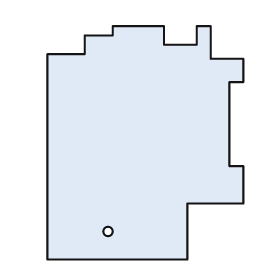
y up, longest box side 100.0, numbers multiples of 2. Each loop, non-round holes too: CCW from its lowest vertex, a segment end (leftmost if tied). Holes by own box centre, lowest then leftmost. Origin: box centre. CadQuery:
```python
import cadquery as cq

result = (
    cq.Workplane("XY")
    .moveTo(-42.0, -50.0)
    .lineTo(18.0, -50.0)
    .lineTo(18.0, -26.0)
    .lineTo(42.0, -26.0)
    .lineTo(42.0, -10.0)
    .lineTo(36.0, -10.0)
    .lineTo(36.0, 26.0)
    .lineTo(42.0, 26.0)
    .lineTo(42.0, 36.0)
    .lineTo(28.0, 36.0)
    .lineTo(28.0, 50.0)
    .lineTo(22.0, 50.0)
    .lineTo(22.0, 42.0)
    .lineTo(8.0, 42.0)
    .lineTo(8.0, 50.0)
    .lineTo(-14.0, 50.0)
    .lineTo(-14.0, 46.0)
    .lineTo(-26.0, 46.0)
    .lineTo(-26.0, 38.0)
    .lineTo(-42.0, 38.0)
    .close()
    .moveTo(-16.0, -38.0)
    .circle(2.0)
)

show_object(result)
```